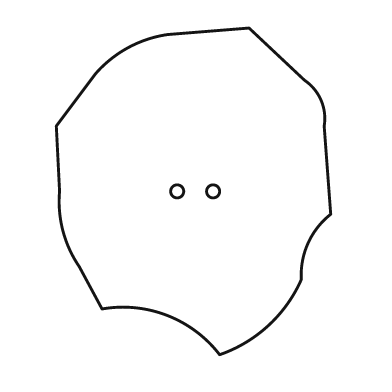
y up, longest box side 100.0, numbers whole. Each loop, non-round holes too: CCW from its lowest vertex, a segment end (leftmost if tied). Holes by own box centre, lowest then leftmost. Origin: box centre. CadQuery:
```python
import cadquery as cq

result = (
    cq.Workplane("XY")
    .moveTo(8.0, -50.0)
    .threePointArc((23.0, -41.0), (33.0, -27.0))
    .threePointArc((35.0, -16.0), (42.0, -7.0))
    .lineTo(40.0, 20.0)
    .threePointArc((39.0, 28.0), (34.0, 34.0))
    .lineTo(17.0, 50.0)
    .lineTo(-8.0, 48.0)
    .threePointArc((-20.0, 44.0), (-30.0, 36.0))
    .lineTo(-42.0, 20.0)
    .lineTo(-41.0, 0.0)
    .threePointArc((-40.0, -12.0), (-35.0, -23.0))
    .lineTo(-28.0, -36.0)
    .threePointArc((-8.0, -38.0), (8.0, -50.0))
    .close()
    .moveTo(-5.0, 0.0)
    .circle(2.0)
    .moveTo(6.0, 0.0)
    .circle(2.0)
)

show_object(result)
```